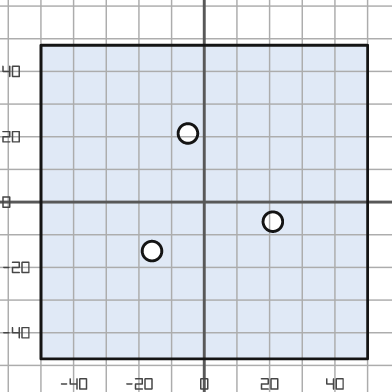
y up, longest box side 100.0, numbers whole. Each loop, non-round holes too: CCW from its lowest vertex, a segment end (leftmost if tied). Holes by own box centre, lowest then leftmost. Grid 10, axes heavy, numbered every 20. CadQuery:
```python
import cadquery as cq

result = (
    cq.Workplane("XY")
    .moveTo(-50.0, -48.0)
    .lineTo(50.0, -48.0)
    .lineTo(50.0, 48.0)
    .lineTo(-50.0, 48.0)
    .close()
    .moveTo(-16.0, -15.0)
    .circle(3.0)
    .moveTo(21.0, -6.0)
    .circle(3.0)
    .moveTo(-5.0, 21.0)
    .circle(3.0)
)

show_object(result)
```